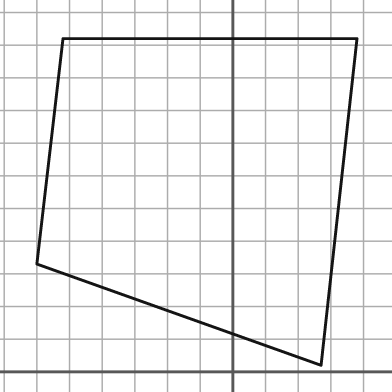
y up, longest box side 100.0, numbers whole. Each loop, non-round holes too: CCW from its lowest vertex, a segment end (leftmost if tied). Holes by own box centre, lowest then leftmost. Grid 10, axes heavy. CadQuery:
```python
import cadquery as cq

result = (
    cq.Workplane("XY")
    .moveTo(27.0, 2.0)
    .lineTo(38.0, 102.0)
    .lineTo(-52.0, 102.0)
    .lineTo(-60.0, 33.0)
    .close()
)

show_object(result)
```